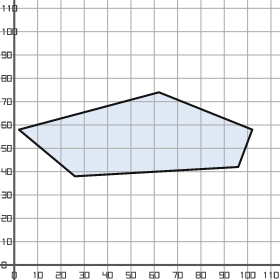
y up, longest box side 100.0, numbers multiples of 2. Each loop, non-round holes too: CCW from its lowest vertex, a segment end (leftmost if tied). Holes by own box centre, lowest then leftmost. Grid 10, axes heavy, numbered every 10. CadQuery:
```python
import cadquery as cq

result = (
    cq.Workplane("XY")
    .moveTo(26.0, 38.0)
    .lineTo(96.0, 42.0)
    .lineTo(102.0, 58.0)
    .lineTo(62.0, 74.0)
    .lineTo(2.0, 58.0)
    .close()
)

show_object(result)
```